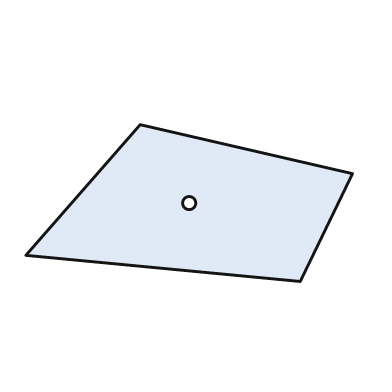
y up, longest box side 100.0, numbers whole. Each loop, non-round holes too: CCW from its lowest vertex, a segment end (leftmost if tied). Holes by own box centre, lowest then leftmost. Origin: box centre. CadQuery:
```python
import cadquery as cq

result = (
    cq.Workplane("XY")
    .moveTo(34.0, -24.0)
    .lineTo(50.0, 9.0)
    .lineTo(-15.0, 24.0)
    .lineTo(-50.0, -16.0)
    .close()
    .moveTo(0.0, 0.0)
    .circle(2.0)
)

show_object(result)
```